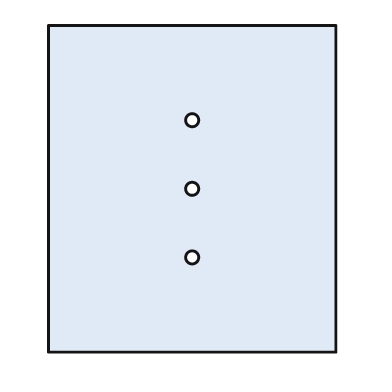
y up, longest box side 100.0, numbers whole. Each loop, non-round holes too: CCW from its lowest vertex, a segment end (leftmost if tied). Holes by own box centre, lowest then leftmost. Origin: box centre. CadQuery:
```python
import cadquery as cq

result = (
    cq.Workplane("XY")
    .moveTo(-44.0, -50.0)
    .lineTo(44.0, -50.0)
    .lineTo(44.0, 50.0)
    .lineTo(-44.0, 50.0)
    .close()
    .moveTo(0.0, -21.0)
    .circle(2.0)
    .moveTo(0.0, 0.0)
    .circle(2.0)
    .moveTo(0.0, 21.0)
    .circle(2.0)
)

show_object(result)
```